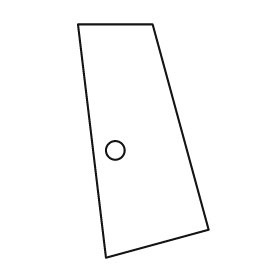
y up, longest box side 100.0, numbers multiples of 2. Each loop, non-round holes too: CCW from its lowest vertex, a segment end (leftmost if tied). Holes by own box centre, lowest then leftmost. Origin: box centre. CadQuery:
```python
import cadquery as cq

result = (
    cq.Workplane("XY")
    .moveTo(-16.0, -50.0)
    .lineTo(28.0, -38.0)
    .lineTo(4.0, 50.0)
    .lineTo(-28.0, 50.0)
    .close()
    .moveTo(-12.0, -4.0)
    .circle(4.0)
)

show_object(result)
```